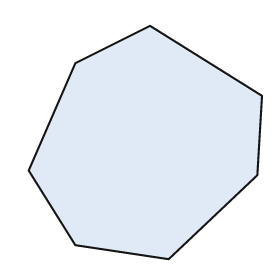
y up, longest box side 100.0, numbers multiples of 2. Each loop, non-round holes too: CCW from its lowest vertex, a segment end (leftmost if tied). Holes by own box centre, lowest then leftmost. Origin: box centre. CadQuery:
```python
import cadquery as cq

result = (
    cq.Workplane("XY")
    .moveTo(10.0, -50.0)
    .lineTo(48.0, -14.0)
    .lineTo(50.0, 20.0)
    .lineTo(2.0, 50.0)
    .lineTo(-30.0, 34.0)
    .lineTo(-50.0, -12.0)
    .lineTo(-30.0, -44.0)
    .close()
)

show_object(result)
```